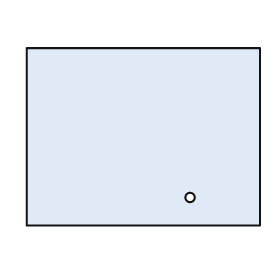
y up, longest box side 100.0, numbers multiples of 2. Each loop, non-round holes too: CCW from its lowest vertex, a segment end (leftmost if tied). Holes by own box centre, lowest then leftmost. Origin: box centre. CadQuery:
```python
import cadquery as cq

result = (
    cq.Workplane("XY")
    .moveTo(-50.0, -38.0)
    .lineTo(50.0, -38.0)
    .lineTo(50.0, 38.0)
    .lineTo(-50.0, 38.0)
    .close()
    .moveTo(20.0, -26.0)
    .circle(2.0)
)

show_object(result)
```